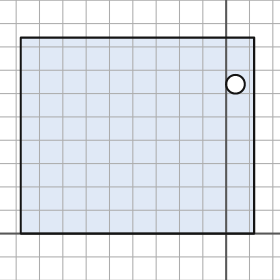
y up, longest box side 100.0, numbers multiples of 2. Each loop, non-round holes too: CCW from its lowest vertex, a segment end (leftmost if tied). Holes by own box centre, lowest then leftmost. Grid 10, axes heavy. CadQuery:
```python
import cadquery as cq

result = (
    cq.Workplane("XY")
    .moveTo(-88.0, 0.0)
    .lineTo(12.0, 0.0)
    .lineTo(12.0, 84.0)
    .lineTo(-88.0, 84.0)
    .close()
    .moveTo(4.0, 64.0)
    .circle(4.0)
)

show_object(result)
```